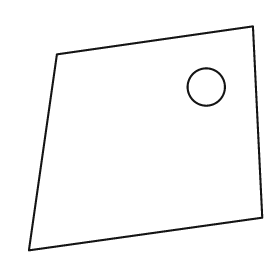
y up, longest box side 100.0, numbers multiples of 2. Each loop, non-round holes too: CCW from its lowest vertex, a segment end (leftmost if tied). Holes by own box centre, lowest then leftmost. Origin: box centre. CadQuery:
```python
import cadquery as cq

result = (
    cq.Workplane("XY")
    .moveTo(-50.0, -48.0)
    .lineTo(50.0, -34.0)
    .lineTo(46.0, 48.0)
    .lineTo(-38.0, 36.0)
    .close()
    .moveTo(26.0, 22.0)
    .circle(8.0)
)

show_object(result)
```